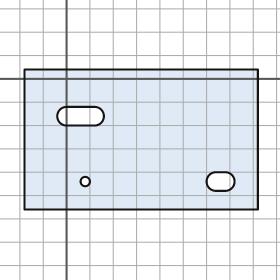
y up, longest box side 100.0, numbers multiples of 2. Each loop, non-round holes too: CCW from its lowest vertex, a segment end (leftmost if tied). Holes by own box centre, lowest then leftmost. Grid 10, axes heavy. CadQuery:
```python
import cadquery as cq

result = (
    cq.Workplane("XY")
    .moveTo(-18.0, -56.0)
    .lineTo(82.0, -56.0)
    .lineTo(82.0, 4.0)
    .lineTo(-18.0, 4.0)
    .close()
    .moveTo(8.0, -44.0)
    .circle(2.0)
    .moveTo(64.0, -48.0)
    .lineTo(68.0, -48.0)
    .threePointArc((72.0, -44.0), (68.0, -40.0))
    .lineTo(64.0, -40.0)
    .threePointArc((60.0, -44.0), (64.0, -48.0))
    .close()
    .moveTo(0.0, -20.0)
    .lineTo(12.0, -20.0)
    .threePointArc((16.0, -16.0), (12.0, -12.0))
    .lineTo(0.0, -12.0)
    .threePointArc((-4.0, -16.0), (0.0, -20.0))
    .close()
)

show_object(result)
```